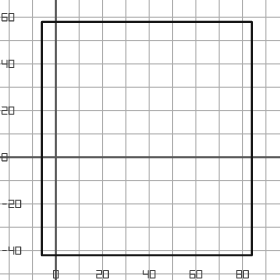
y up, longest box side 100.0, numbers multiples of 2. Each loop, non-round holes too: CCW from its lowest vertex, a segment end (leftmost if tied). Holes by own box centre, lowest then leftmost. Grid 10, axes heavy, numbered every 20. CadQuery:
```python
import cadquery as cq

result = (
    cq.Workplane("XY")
    .moveTo(-6.0, -42.0)
    .lineTo(84.0, -42.0)
    .lineTo(84.0, 58.0)
    .lineTo(-6.0, 58.0)
    .close()
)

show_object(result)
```